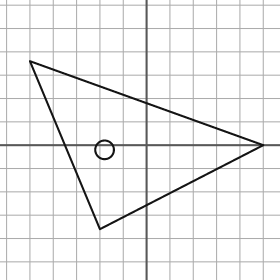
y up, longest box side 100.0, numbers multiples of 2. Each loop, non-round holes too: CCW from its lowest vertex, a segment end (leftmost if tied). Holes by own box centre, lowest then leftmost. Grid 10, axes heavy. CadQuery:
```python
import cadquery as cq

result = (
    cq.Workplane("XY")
    .moveTo(-20.0, -36.0)
    .lineTo(50.0, 0.0)
    .lineTo(-50.0, 36.0)
    .close()
    .moveTo(-18.0, -2.0)
    .circle(4.0)
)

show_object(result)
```